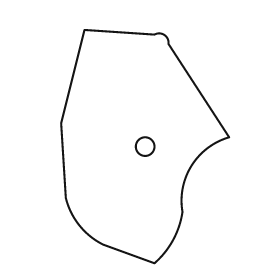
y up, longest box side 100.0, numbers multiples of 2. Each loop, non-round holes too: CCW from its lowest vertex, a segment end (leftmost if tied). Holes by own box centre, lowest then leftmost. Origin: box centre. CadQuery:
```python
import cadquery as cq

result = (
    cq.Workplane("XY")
    .moveTo(4.0, -50.0)
    .threePointArc((12.0, -40.0), (16.0, -28.0))
    .threePointArc((20.0, -8.0), (36.0, 4.0))
    .lineTo(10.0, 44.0)
    .threePointArc((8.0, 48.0), (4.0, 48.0))
    .lineTo(-26.0, 50.0)
    .lineTo(-36.0, 10.0)
    .lineTo(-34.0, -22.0)
    .threePointArc((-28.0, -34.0), (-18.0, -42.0))
    .close()
    .moveTo(0.0, 0.0)
    .circle(4.0)
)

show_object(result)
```